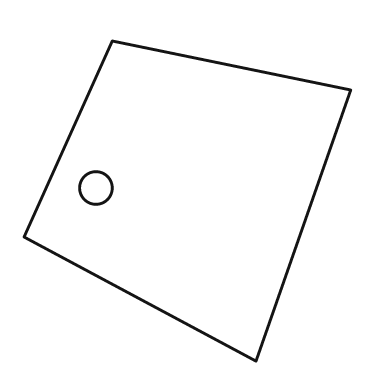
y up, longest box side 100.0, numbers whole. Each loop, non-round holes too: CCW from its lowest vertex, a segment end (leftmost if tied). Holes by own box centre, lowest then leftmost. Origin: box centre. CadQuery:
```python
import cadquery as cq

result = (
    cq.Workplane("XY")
    .moveTo(21.0, -49.0)
    .lineTo(50.0, 34.0)
    .lineTo(-23.0, 49.0)
    .lineTo(-50.0, -11.0)
    .close()
    .moveTo(-28.0, 4.0)
    .circle(5.0)
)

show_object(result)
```